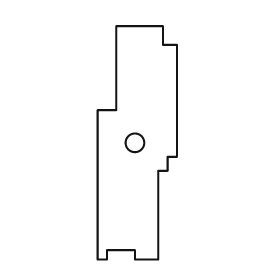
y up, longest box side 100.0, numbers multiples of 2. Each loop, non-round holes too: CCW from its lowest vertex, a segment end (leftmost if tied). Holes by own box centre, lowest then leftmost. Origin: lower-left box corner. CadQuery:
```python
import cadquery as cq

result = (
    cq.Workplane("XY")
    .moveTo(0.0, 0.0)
    .lineTo(4.0, 0.0)
    .lineTo(4.0, 4.0)
    .lineTo(16.0, 4.0)
    .lineTo(16.0, 0.0)
    .lineTo(26.0, 0.0)
    .lineTo(26.0, 38.0)
    .lineTo(30.0, 38.0)
    .lineTo(30.0, 44.0)
    .lineTo(34.0, 44.0)
    .lineTo(34.0, 92.0)
    .lineTo(28.0, 92.0)
    .lineTo(28.0, 100.0)
    .lineTo(8.0, 100.0)
    .lineTo(8.0, 64.0)
    .lineTo(0.0, 64.0)
    .close()
    .moveTo(16.0, 50.0)
    .circle(4.0)
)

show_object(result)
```